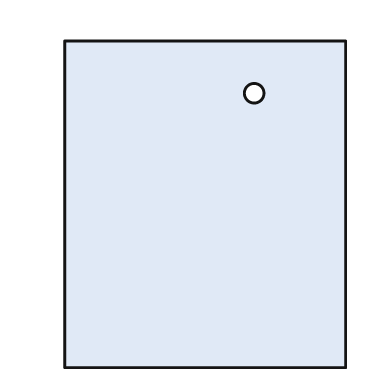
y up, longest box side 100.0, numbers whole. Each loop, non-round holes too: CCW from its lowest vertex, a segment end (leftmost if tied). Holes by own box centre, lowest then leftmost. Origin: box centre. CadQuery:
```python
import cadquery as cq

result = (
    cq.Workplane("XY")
    .moveTo(-43.0, -50.0)
    .lineTo(43.0, -50.0)
    .lineTo(43.0, 50.0)
    .lineTo(-43.0, 50.0)
    .close()
    .moveTo(15.0, 34.0)
    .circle(3.0)
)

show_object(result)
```